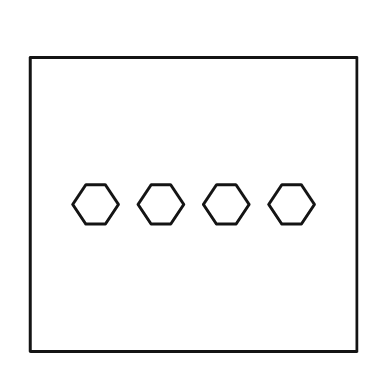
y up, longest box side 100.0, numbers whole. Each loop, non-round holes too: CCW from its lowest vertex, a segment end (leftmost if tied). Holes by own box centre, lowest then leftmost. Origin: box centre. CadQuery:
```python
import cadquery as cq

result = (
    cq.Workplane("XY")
    .moveTo(-50.0, -45.0)
    .lineTo(50.0, -45.0)
    .lineTo(50.0, 45.0)
    .lineTo(-50.0, 45.0)
    .close()
    .moveTo(-33.0, -6.0)
    .lineTo(-27.0, -6.0)
    .lineTo(-23.0, 0.0)
    .lineTo(-27.0, 6.0)
    .lineTo(-33.0, 6.0)
    .lineTo(-37.0, 0.0)
    .close()
    .moveTo(-13.0, -6.0)
    .lineTo(-7.0, -6.0)
    .lineTo(-3.0, 0.0)
    .lineTo(-7.0, 6.0)
    .lineTo(-13.0, 6.0)
    .lineTo(-17.0, 0.0)
    .close()
    .moveTo(7.0, -6.0)
    .lineTo(13.0, -6.0)
    .lineTo(17.0, 0.0)
    .lineTo(13.0, 6.0)
    .lineTo(7.0, 6.0)
    .lineTo(3.0, 0.0)
    .close()
    .moveTo(27.0, -6.0)
    .lineTo(33.0, -6.0)
    .lineTo(37.0, 0.0)
    .lineTo(33.0, 6.0)
    .lineTo(27.0, 6.0)
    .lineTo(23.0, 0.0)
    .close()
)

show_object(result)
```